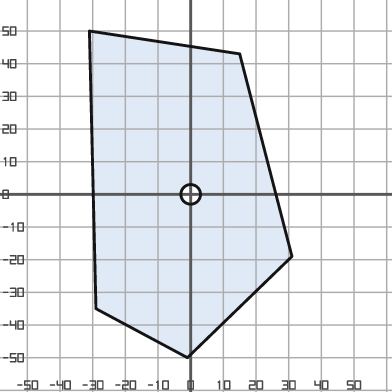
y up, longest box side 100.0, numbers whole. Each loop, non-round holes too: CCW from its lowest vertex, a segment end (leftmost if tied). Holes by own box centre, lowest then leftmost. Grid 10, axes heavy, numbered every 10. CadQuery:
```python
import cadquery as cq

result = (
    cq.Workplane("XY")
    .moveTo(-1.0, -50.0)
    .lineTo(31.0, -19.0)
    .lineTo(15.0, 43.0)
    .lineTo(-31.0, 50.0)
    .lineTo(-29.0, -35.0)
    .close()
    .moveTo(0.0, 0.0)
    .circle(3.0)
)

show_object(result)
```